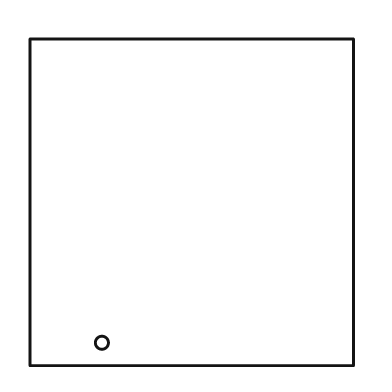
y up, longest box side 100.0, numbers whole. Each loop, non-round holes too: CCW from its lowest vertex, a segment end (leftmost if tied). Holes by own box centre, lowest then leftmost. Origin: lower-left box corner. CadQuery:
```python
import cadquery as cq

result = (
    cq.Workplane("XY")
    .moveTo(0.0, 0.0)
    .lineTo(99.0, 0.0)
    .lineTo(99.0, 100.0)
    .lineTo(0.0, 100.0)
    .close()
    .moveTo(22.0, 7.0)
    .circle(2.0)
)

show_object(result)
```